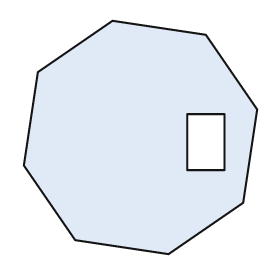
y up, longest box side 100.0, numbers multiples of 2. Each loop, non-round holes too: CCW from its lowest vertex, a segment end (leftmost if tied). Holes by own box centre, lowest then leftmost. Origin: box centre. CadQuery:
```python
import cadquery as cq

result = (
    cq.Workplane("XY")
    .moveTo(12.0, -50.0)
    .lineTo(44.0, -28.0)
    .lineTo(50.0, 12.0)
    .lineTo(28.0, 44.0)
    .lineTo(-12.0, 50.0)
    .lineTo(-44.0, 28.0)
    .lineTo(-50.0, -12.0)
    .lineTo(-28.0, -44.0)
    .close()
    .moveTo(20.0, -14.0)
    .lineTo(36.0, -14.0)
    .lineTo(36.0, 10.0)
    .lineTo(20.0, 10.0)
    .close()
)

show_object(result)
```